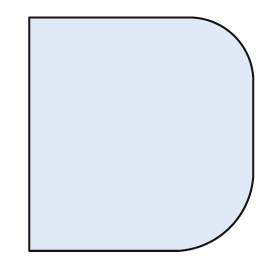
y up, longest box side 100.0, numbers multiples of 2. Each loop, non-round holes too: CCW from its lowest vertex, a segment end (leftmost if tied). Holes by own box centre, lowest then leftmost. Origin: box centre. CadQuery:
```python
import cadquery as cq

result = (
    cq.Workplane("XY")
    .moveTo(-48.0, -50.0)
    .lineTo(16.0, -50.0)
    .threePointArc((38.0, -40.0), (48.0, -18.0))
    .lineTo(48.0, 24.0)
    .threePointArc((40.0, 42.0), (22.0, 50.0))
    .lineTo(-48.0, 50.0)
    .close()
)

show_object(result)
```